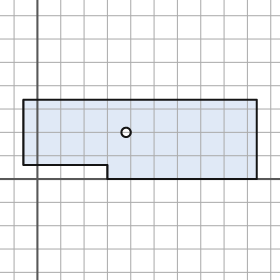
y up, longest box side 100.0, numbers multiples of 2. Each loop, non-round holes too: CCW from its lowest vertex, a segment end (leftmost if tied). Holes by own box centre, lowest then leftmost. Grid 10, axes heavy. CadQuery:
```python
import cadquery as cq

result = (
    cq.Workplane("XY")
    .moveTo(30.0, 0.0)
    .lineTo(94.0, 0.0)
    .lineTo(94.0, 34.0)
    .lineTo(-6.0, 34.0)
    .lineTo(-6.0, 6.0)
    .lineTo(30.0, 6.0)
    .close()
    .moveTo(38.0, 20.0)
    .circle(2.0)
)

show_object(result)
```